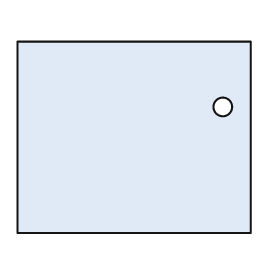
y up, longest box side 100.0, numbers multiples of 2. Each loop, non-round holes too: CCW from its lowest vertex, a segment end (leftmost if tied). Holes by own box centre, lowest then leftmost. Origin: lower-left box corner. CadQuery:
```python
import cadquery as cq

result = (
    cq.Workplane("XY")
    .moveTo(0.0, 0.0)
    .lineTo(100.0, 0.0)
    .lineTo(100.0, 82.0)
    .lineTo(0.0, 82.0)
    .close()
    .moveTo(88.0, 54.0)
    .circle(4.0)
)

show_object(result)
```